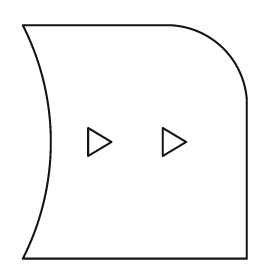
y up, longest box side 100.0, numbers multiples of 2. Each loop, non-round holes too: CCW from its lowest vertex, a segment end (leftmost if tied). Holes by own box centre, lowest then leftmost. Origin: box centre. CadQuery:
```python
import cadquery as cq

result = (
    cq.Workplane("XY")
    .moveTo(-48.0, -50.0)
    .lineTo(48.0, -50.0)
    .lineTo(48.0, 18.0)
    .threePointArc((38.0, 40.0), (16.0, 50.0))
    .lineTo(-48.0, 50.0)
    .threePointArc((-36.0, 0.0), (-48.0, -50.0))
    .close()
    .moveTo(-20.0, -6.0)
    .lineTo(-10.0, 0.0)
    .lineTo(-20.0, 6.0)
    .close()
    .moveTo(12.0, -6.0)
    .lineTo(22.0, 0.0)
    .lineTo(12.0, 6.0)
    .close()
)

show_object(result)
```